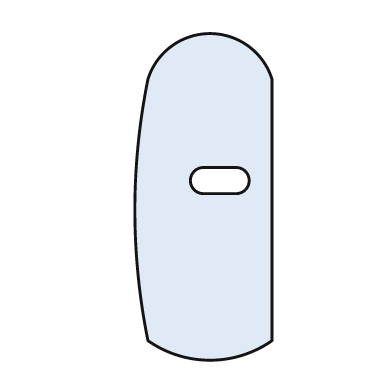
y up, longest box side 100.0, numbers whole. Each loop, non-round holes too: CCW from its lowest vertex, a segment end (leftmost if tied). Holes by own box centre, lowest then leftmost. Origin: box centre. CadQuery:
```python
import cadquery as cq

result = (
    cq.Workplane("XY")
    .moveTo(-17.0, -44.0)
    .threePointArc((2.0, -50.0), (21.0, -44.0))
    .lineTo(21.0, 36.0)
    .threePointArc((2.0, 50.0), (-17.0, 36.0))
    .threePointArc((-21.0, -4.0), (-17.0, -44.0))
    .close()
    .moveTo(0.0, 1.0)
    .lineTo(10.0, 1.0)
    .threePointArc((14.0, 5.0), (10.0, 9.0))
    .lineTo(0.0, 9.0)
    .threePointArc((-4.0, 5.0), (0.0, 1.0))
    .close()
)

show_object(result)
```